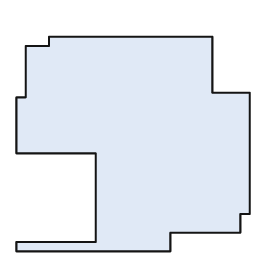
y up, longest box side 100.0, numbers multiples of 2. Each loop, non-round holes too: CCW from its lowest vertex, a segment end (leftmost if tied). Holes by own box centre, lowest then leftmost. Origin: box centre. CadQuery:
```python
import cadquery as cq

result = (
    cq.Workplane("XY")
    .moveTo(-50.0, -46.0)
    .lineTo(16.0, -46.0)
    .lineTo(16.0, -38.0)
    .lineTo(46.0, -38.0)
    .lineTo(46.0, -30.0)
    .lineTo(50.0, -30.0)
    .lineTo(50.0, 22.0)
    .lineTo(34.0, 22.0)
    .lineTo(34.0, 46.0)
    .lineTo(-36.0, 46.0)
    .lineTo(-36.0, 42.0)
    .lineTo(-46.0, 42.0)
    .lineTo(-46.0, 20.0)
    .lineTo(-50.0, 20.0)
    .lineTo(-50.0, -4.0)
    .lineTo(-16.0, -4.0)
    .lineTo(-16.0, -42.0)
    .lineTo(-50.0, -42.0)
    .close()
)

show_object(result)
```